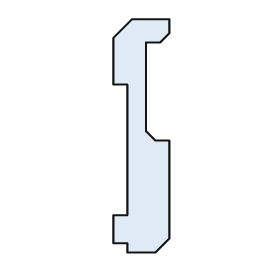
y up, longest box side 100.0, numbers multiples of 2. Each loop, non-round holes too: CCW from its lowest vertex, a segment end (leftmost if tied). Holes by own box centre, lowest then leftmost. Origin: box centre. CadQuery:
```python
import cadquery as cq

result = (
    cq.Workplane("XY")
    .moveTo(-6.0, -50.0)
    .lineTo(6.0, -50.0)
    .lineTo(12.0, -44.0)
    .lineTo(12.0, -2.0)
    .lineTo(6.0, -2.0)
    .lineTo(2.0, 2.0)
    .lineTo(2.0, 40.0)
    .lineTo(8.0, 40.0)
    .lineTo(12.0, 44.0)
    .lineTo(12.0, 50.0)
    .lineTo(-4.0, 50.0)
    .lineTo(-12.0, 42.0)
    .lineTo(-12.0, 22.0)
    .lineTo(-6.0, 22.0)
    .lineTo(-6.0, -34.0)
    .lineTo(-12.0, -34.0)
    .lineTo(-12.0, -46.0)
    .lineTo(-6.0, -46.0)
    .close()
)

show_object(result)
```